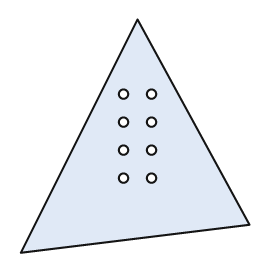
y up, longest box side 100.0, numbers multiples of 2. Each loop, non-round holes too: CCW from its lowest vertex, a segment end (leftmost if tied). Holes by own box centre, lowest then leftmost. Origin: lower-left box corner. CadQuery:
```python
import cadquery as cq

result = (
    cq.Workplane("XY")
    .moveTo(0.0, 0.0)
    .lineTo(98.0, 12.0)
    .lineTo(50.0, 100.0)
    .close()
    .moveTo(44.0, 32.0)
    .circle(2.0)
    .moveTo(56.0, 32.0)
    .circle(2.0)
    .moveTo(44.0, 44.0)
    .circle(2.0)
    .moveTo(56.0, 44.0)
    .circle(2.0)
    .moveTo(44.0, 56.0)
    .circle(2.0)
    .moveTo(56.0, 56.0)
    .circle(2.0)
    .moveTo(44.0, 68.0)
    .circle(2.0)
    .moveTo(56.0, 68.0)
    .circle(2.0)
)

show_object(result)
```